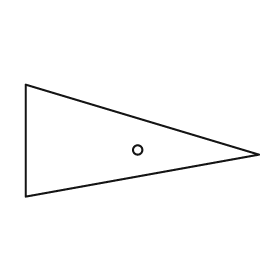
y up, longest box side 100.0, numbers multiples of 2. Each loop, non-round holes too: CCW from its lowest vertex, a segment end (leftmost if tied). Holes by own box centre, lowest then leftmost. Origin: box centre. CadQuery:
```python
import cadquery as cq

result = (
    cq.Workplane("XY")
    .moveTo(-50.0, -24.0)
    .lineTo(50.0, -6.0)
    .lineTo(-50.0, 24.0)
    .close()
    .moveTo(-2.0, -4.0)
    .circle(2.0)
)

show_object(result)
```